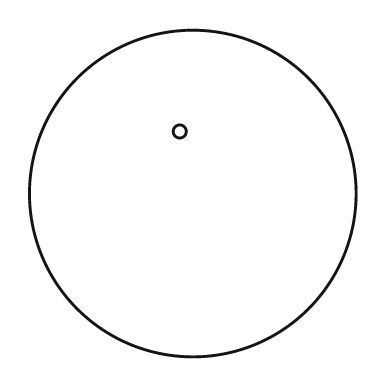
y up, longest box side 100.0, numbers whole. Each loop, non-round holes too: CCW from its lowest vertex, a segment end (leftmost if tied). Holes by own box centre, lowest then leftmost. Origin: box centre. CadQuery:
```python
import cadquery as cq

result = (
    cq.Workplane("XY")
    .moveTo(0.0, 0.0)
    .circle(50.0)
    .moveTo(-4.0, 19.0)
    .circle(2.0)
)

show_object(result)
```